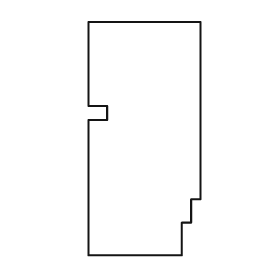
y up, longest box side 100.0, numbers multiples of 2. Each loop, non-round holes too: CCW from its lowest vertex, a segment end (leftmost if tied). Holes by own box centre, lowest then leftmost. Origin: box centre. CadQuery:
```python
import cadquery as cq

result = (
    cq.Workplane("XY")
    .moveTo(-24.0, -50.0)
    .lineTo(16.0, -50.0)
    .lineTo(16.0, -36.0)
    .lineTo(20.0, -36.0)
    .lineTo(20.0, -26.0)
    .lineTo(24.0, -26.0)
    .lineTo(24.0, 50.0)
    .lineTo(-24.0, 50.0)
    .lineTo(-24.0, 14.0)
    .lineTo(-16.0, 14.0)
    .lineTo(-16.0, 8.0)
    .lineTo(-24.0, 8.0)
    .close()
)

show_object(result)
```